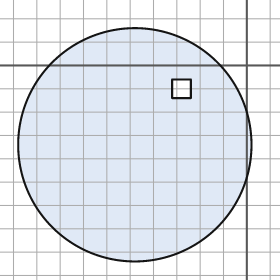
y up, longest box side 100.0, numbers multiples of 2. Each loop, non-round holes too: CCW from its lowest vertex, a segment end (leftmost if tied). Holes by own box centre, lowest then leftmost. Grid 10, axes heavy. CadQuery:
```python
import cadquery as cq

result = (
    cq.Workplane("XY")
    .moveTo(-48.0, -34.0)
    .circle(50.0)
    .moveTo(-32.0, -14.0)
    .lineTo(-24.0, -14.0)
    .lineTo(-24.0, -6.0)
    .lineTo(-32.0, -6.0)
    .close()
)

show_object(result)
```